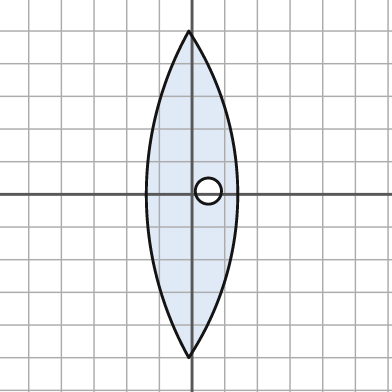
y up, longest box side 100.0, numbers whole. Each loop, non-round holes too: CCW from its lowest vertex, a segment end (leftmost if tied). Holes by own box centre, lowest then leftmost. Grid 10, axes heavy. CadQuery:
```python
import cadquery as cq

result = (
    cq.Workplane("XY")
    .moveTo(-1.0, -50.0)
    .threePointArc((14.0, 0.0), (-1.0, 50.0))
    .threePointArc((-14.0, 0.0), (-1.0, -50.0))
    .close()
    .moveTo(5.0, 1.0)
    .circle(4.0)
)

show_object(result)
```